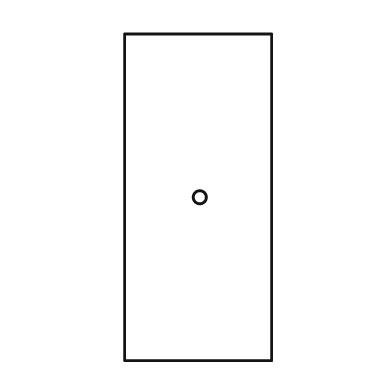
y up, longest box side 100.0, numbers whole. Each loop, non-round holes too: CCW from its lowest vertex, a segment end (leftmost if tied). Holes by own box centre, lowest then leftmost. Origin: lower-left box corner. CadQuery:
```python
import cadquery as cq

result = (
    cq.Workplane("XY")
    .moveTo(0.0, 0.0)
    .lineTo(45.0, 0.0)
    .lineTo(45.0, 100.0)
    .lineTo(0.0, 100.0)
    .close()
    .moveTo(23.0, 50.0)
    .circle(2.0)
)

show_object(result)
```